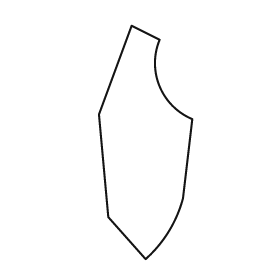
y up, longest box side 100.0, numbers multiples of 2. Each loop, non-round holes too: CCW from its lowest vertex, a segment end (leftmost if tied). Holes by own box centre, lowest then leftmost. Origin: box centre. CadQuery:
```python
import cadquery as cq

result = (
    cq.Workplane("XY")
    .moveTo(0.0, -50.0)
    .threePointArc((10.0, -38.0), (16.0, -24.0))
    .lineTo(20.0, 10.0)
    .threePointArc((6.0, 24.0), (6.0, 44.0))
    .lineTo(-6.0, 50.0)
    .lineTo(-20.0, 12.0)
    .lineTo(-16.0, -32.0)
    .close()
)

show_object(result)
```